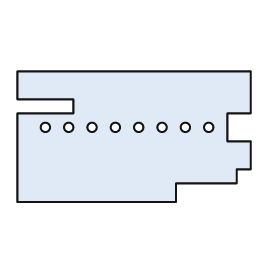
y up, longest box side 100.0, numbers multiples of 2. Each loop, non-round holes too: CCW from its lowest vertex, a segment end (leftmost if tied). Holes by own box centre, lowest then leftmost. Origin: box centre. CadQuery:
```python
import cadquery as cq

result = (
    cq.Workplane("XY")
    .moveTo(-50.0, -28.0)
    .lineTo(18.0, -28.0)
    .lineTo(18.0, -20.0)
    .lineTo(44.0, -20.0)
    .lineTo(44.0, -14.0)
    .lineTo(50.0, -14.0)
    .lineTo(50.0, -2.0)
    .lineTo(40.0, -2.0)
    .lineTo(40.0, 10.0)
    .lineTo(50.0, 10.0)
    .lineTo(50.0, 28.0)
    .lineTo(-50.0, 28.0)
    .lineTo(-50.0, 16.0)
    .lineTo(-26.0, 16.0)
    .lineTo(-26.0, 10.0)
    .lineTo(-50.0, 10.0)
    .close()
    .moveTo(-38.0, 4.0)
    .circle(2.0)
    .moveTo(-28.0, 4.0)
    .circle(2.0)
    .moveTo(-18.0, 4.0)
    .circle(2.0)
    .moveTo(-8.0, 4.0)
    .circle(2.0)
    .moveTo(2.0, 4.0)
    .circle(2.0)
    .moveTo(12.0, 4.0)
    .circle(2.0)
    .moveTo(22.0, 4.0)
    .circle(2.0)
    .moveTo(32.0, 4.0)
    .circle(2.0)
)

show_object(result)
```